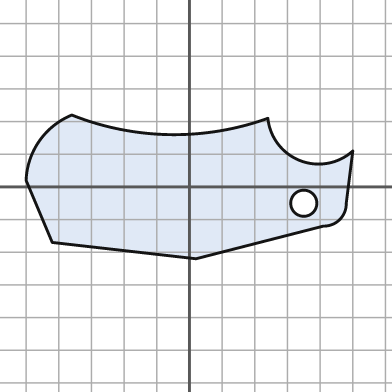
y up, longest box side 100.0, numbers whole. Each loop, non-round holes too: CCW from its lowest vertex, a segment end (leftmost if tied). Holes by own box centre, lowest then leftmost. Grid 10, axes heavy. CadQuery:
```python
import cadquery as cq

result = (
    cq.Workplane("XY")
    .moveTo(2.0, -22.0)
    .lineTo(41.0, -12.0)
    .threePointArc((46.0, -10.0), (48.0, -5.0))
    .lineTo(50.0, 11.0)
    .threePointArc((34.0, 8.0), (24.0, 21.0))
    .threePointArc((-6.0, 16.0), (-36.0, 22.0))
    .threePointArc((-46.0, 14.0), (-50.0, 2.0))
    .lineTo(-42.0, -17.0)
    .close()
    .moveTo(35.0, -5.0)
    .circle(4.0)
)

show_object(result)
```